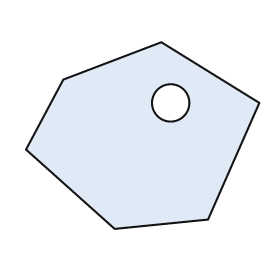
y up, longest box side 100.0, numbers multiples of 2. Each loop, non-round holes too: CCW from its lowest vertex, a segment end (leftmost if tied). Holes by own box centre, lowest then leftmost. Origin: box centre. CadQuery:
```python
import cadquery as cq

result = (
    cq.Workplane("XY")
    .moveTo(-12.0, -40.0)
    .lineTo(28.0, -36.0)
    .lineTo(50.0, 14.0)
    .lineTo(8.0, 40.0)
    .lineTo(-34.0, 24.0)
    .lineTo(-50.0, -6.0)
    .close()
    .moveTo(12.0, 14.0)
    .circle(8.0)
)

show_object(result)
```